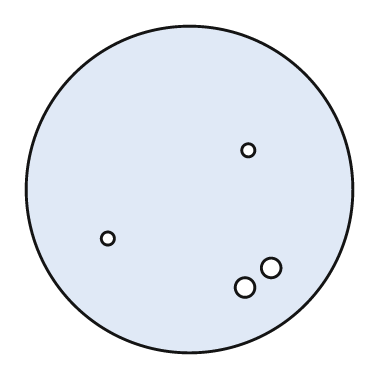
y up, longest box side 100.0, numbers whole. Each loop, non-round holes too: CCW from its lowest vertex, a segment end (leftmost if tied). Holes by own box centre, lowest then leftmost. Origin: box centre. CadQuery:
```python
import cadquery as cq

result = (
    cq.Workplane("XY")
    .moveTo(0.0, 0.0)
    .circle(50.0)
    .moveTo(17.0, -30.0)
    .circle(3.0)
    .moveTo(25.0, -24.0)
    .circle(3.0)
    .moveTo(-25.0, -15.0)
    .circle(2.0)
    .moveTo(18.0, 12.0)
    .circle(2.0)
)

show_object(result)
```